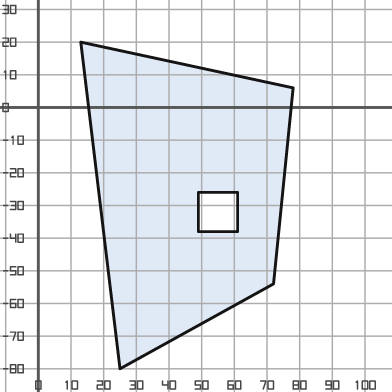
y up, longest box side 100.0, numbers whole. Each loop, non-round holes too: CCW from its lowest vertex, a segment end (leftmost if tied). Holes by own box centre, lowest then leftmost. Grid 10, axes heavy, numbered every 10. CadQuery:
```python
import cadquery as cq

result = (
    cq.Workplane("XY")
    .moveTo(25.0, -80.0)
    .lineTo(72.0, -54.0)
    .lineTo(78.0, 6.0)
    .lineTo(13.0, 20.0)
    .close()
    .moveTo(49.0, -38.0)
    .lineTo(61.0, -38.0)
    .lineTo(61.0, -26.0)
    .lineTo(49.0, -26.0)
    .close()
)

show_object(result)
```